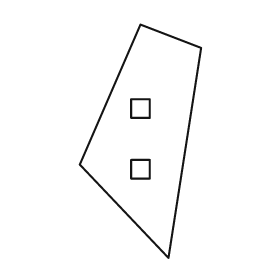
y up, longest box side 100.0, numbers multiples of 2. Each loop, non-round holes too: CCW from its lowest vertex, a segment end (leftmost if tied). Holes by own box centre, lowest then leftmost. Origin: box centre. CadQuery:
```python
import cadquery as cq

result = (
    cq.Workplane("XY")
    .moveTo(12.0, -50.0)
    .lineTo(26.0, 40.0)
    .lineTo(0.0, 50.0)
    .lineTo(-26.0, -10.0)
    .close()
    .moveTo(-4.0, -16.0)
    .lineTo(4.0, -16.0)
    .lineTo(4.0, -8.0)
    .lineTo(-4.0, -8.0)
    .close()
    .moveTo(-4.0, 10.0)
    .lineTo(4.0, 10.0)
    .lineTo(4.0, 18.0)
    .lineTo(-4.0, 18.0)
    .close()
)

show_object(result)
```